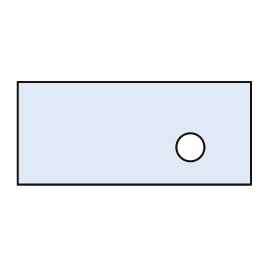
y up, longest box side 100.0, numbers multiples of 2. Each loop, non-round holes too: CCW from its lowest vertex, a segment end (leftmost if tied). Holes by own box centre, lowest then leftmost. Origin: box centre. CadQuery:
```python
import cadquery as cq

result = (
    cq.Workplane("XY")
    .moveTo(-50.0, -22.0)
    .lineTo(50.0, -22.0)
    .lineTo(50.0, 22.0)
    .lineTo(-50.0, 22.0)
    .close()
    .moveTo(24.0, -6.0)
    .circle(6.0)
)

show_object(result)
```